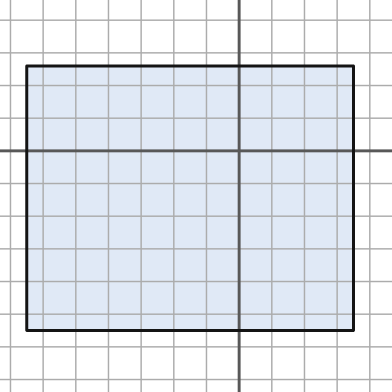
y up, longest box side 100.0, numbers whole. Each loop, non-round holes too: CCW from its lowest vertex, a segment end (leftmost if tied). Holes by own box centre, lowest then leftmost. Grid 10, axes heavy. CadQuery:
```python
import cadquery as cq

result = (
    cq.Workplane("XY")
    .moveTo(-65.0, -55.0)
    .lineTo(35.0, -55.0)
    .lineTo(35.0, 26.0)
    .lineTo(-65.0, 26.0)
    .close()
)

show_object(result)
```